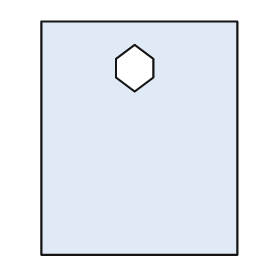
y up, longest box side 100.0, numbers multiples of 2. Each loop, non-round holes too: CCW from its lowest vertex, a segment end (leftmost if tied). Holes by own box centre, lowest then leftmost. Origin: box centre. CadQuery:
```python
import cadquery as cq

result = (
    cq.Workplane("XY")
    .moveTo(-42.0, -50.0)
    .lineTo(42.0, -50.0)
    .lineTo(42.0, 50.0)
    .lineTo(-42.0, 50.0)
    .close()
    .moveTo(-2.0, 20.0)
    .lineTo(6.0, 26.0)
    .lineTo(6.0, 34.0)
    .lineTo(-2.0, 40.0)
    .lineTo(-10.0, 34.0)
    .lineTo(-10.0, 26.0)
    .close()
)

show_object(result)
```